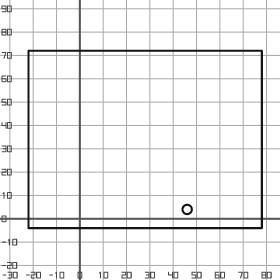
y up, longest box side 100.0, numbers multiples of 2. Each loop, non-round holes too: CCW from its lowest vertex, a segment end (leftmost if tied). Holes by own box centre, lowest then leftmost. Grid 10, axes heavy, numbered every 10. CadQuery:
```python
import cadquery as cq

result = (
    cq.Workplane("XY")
    .moveTo(-22.0, -4.0)
    .lineTo(78.0, -4.0)
    .lineTo(78.0, 72.0)
    .lineTo(-22.0, 72.0)
    .close()
    .moveTo(46.0, 4.0)
    .circle(2.0)
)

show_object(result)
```